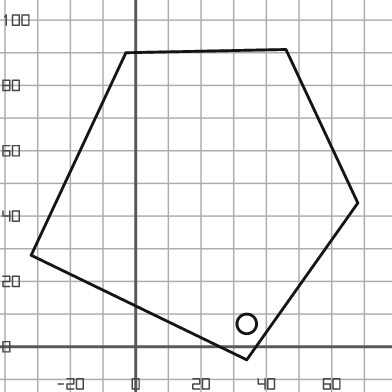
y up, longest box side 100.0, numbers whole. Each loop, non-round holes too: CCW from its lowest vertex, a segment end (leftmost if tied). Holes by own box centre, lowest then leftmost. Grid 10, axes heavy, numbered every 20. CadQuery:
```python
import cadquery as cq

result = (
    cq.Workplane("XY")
    .moveTo(34.0, -4.0)
    .lineTo(68.0, 44.0)
    .lineTo(46.0, 91.0)
    .lineTo(-3.0, 90.0)
    .lineTo(-32.0, 28.0)
    .close()
    .moveTo(34.0, 7.0)
    .circle(3.0)
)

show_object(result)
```